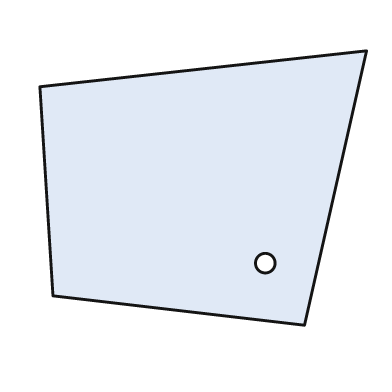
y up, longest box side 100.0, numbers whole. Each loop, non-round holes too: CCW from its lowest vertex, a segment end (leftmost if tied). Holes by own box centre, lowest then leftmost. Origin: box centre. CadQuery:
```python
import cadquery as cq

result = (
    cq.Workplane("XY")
    .moveTo(31.0, -42.0)
    .lineTo(50.0, 42.0)
    .lineTo(-50.0, 31.0)
    .lineTo(-46.0, -33.0)
    .close()
    .moveTo(19.0, -23.0)
    .circle(3.0)
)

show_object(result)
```